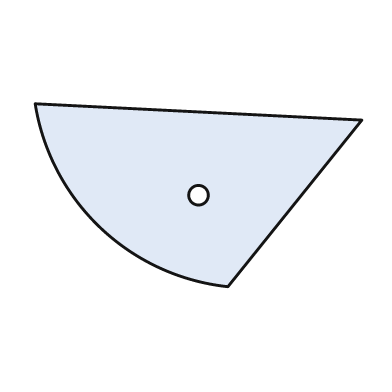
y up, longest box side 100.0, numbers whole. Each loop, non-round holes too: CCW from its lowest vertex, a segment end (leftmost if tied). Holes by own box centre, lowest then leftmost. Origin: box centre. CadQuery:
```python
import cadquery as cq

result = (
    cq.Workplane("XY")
    .moveTo(9.0, -28.0)
    .lineTo(50.0, 23.0)
    .lineTo(-50.0, 28.0)
    .threePointArc((-30.0, -10.0), (9.0, -28.0))
    .close()
    .moveTo(0.0, 0.0)
    .circle(3.0)
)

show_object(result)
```